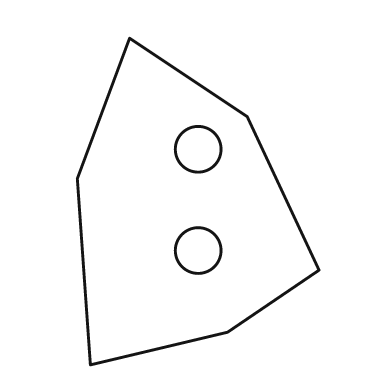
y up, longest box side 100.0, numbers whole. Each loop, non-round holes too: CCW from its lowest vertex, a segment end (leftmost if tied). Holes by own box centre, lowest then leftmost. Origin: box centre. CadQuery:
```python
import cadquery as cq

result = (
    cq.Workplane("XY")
    .moveTo(-33.0, -50.0)
    .lineTo(9.0, -40.0)
    .lineTo(37.0, -21.0)
    .lineTo(15.0, 26.0)
    .lineTo(-21.0, 50.0)
    .lineTo(-37.0, 7.0)
    .close()
    .moveTo(0.0, -15.0)
    .circle(7.0)
    .moveTo(0.0, 16.0)
    .circle(7.0)
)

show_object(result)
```